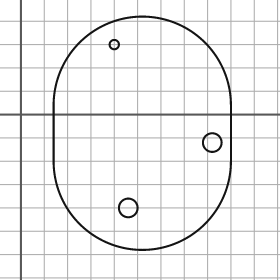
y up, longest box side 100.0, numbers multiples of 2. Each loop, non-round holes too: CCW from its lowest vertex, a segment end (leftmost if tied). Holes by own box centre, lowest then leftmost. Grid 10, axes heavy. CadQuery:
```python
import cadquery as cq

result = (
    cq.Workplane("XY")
    .moveTo(14.0, -20.0)
    .threePointArc((52.0, -58.0), (90.0, -20.0))
    .lineTo(90.0, 4.0)
    .threePointArc((52.0, 42.0), (14.0, 4.0))
    .close()
    .moveTo(46.0, -40.0)
    .circle(4.0)
    .moveTo(82.0, -12.0)
    .circle(4.0)
    .moveTo(40.0, 30.0)
    .circle(2.0)
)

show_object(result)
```